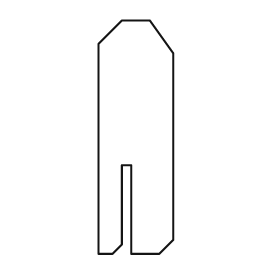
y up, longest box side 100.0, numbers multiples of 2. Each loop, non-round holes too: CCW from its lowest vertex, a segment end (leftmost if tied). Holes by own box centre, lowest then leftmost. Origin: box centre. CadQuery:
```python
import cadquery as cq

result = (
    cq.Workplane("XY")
    .moveTo(-16.0, -50.0)
    .lineTo(-10.0, -50.0)
    .lineTo(-6.0, -46.0)
    .lineTo(-6.0, -12.0)
    .lineTo(-2.0, -12.0)
    .lineTo(-2.0, -50.0)
    .lineTo(10.0, -50.0)
    .lineTo(16.0, -44.0)
    .lineTo(16.0, 36.0)
    .lineTo(6.0, 50.0)
    .lineTo(-6.0, 50.0)
    .lineTo(-16.0, 40.0)
    .close()
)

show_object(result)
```